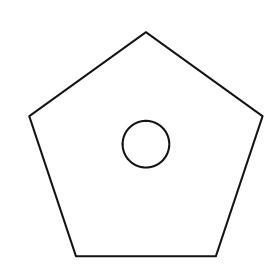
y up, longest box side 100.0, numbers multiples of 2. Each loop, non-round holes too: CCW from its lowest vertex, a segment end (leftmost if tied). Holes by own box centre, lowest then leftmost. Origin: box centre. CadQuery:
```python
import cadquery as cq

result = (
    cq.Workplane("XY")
    .moveTo(-30.0, -48.0)
    .lineTo(30.0, -48.0)
    .lineTo(50.0, 12.0)
    .lineTo(0.0, 48.0)
    .lineTo(-50.0, 12.0)
    .close()
    .moveTo(0.0, 0.0)
    .circle(10.0)
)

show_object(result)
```